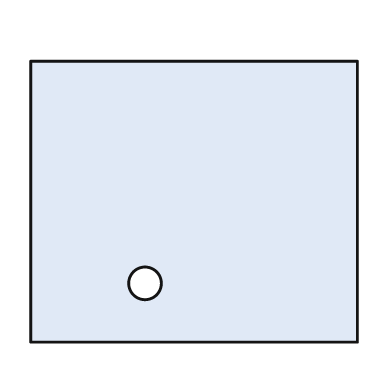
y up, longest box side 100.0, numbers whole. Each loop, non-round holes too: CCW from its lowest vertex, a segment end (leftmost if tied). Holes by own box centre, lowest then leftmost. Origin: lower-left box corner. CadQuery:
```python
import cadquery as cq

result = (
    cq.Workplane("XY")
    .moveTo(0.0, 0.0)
    .lineTo(100.0, 0.0)
    .lineTo(100.0, 86.0)
    .lineTo(0.0, 86.0)
    .close()
    .moveTo(35.0, 18.0)
    .circle(5.0)
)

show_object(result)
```